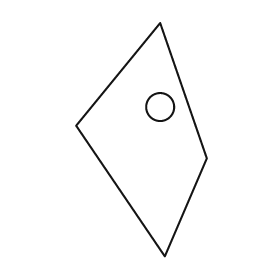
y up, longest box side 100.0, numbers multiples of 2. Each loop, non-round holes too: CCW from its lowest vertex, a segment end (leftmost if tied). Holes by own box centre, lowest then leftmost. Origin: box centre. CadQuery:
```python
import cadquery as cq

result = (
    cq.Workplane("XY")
    .moveTo(10.0, -50.0)
    .lineTo(28.0, -8.0)
    .lineTo(8.0, 50.0)
    .lineTo(-28.0, 6.0)
    .close()
    .moveTo(8.0, 14.0)
    .circle(6.0)
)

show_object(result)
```